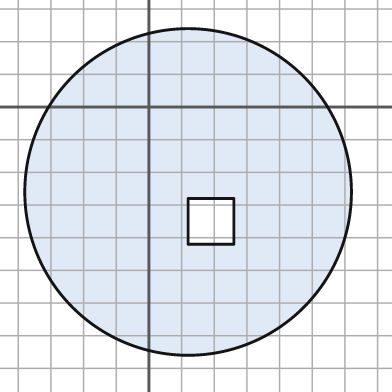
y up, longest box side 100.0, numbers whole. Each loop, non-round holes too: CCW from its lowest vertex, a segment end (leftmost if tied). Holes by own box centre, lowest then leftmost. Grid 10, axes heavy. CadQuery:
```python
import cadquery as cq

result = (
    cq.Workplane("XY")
    .moveTo(12.0, -26.0)
    .circle(50.0)
    .moveTo(12.0, -42.0)
    .lineTo(26.0, -42.0)
    .lineTo(26.0, -28.0)
    .lineTo(12.0, -28.0)
    .close()
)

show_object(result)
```